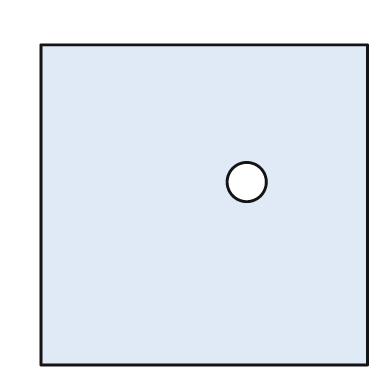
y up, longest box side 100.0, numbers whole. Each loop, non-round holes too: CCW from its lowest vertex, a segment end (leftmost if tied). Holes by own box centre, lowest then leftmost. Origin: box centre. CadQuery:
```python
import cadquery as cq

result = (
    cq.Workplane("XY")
    .moveTo(-50.0, -49.0)
    .lineTo(50.0, -49.0)
    .lineTo(50.0, 49.0)
    .lineTo(-50.0, 49.0)
    .close()
    .moveTo(13.0, 7.0)
    .circle(6.0)
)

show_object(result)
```